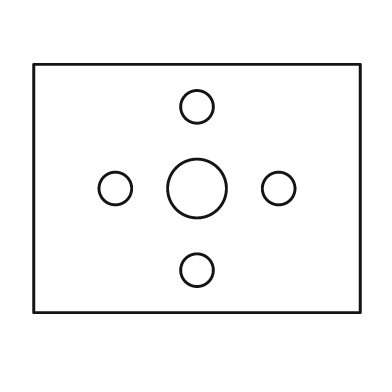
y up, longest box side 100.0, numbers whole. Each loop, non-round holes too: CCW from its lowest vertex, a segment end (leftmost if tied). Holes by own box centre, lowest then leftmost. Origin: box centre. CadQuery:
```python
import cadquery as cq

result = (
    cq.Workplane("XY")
    .moveTo(-50.0, -38.0)
    .lineTo(50.0, -38.0)
    .lineTo(50.0, 38.0)
    .lineTo(-50.0, 38.0)
    .close()
    .moveTo(0.0, -25.0)
    .circle(5.0)
    .moveTo(-25.0, 0.0)
    .circle(5.0)
    .moveTo(0.0, 0.0)
    .circle(9.0)
    .moveTo(25.0, 0.0)
    .circle(5.0)
    .moveTo(0.0, 25.0)
    .circle(5.0)
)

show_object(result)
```